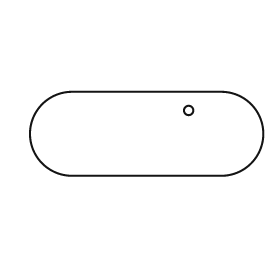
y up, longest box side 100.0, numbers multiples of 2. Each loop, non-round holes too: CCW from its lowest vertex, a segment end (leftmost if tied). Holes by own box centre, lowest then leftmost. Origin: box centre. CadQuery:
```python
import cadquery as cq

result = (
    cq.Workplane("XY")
    .moveTo(-32.0, -18.0)
    .lineTo(32.0, -18.0)
    .threePointArc((50.0, 0.0), (32.0, 18.0))
    .lineTo(-32.0, 18.0)
    .threePointArc((-50.0, 0.0), (-32.0, -18.0))
    .close()
    .moveTo(18.0, 10.0)
    .circle(2.0)
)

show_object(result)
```